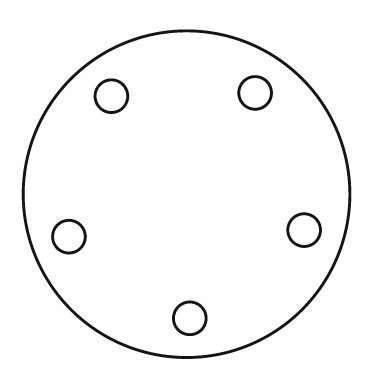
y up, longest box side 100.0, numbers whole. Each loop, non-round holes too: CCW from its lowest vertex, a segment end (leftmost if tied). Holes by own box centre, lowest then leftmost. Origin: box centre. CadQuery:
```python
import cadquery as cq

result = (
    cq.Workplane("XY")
    .moveTo(0.0, 0.0)
    .circle(50.0)
    .moveTo(1.0, -38.0)
    .circle(5.0)
    .moveTo(-36.0, -13.0)
    .circle(5.0)
    .moveTo(36.0, -11.0)
    .circle(5.0)
    .moveTo(-23.0, 30.0)
    .circle(5.0)
    .moveTo(21.0, 31.0)
    .circle(5.0)
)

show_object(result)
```